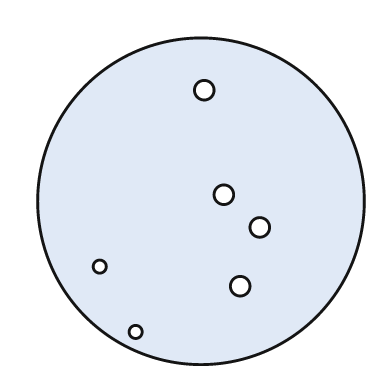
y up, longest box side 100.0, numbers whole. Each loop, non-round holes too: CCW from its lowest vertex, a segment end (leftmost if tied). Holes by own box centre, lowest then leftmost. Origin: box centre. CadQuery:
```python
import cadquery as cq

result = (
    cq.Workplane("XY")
    .moveTo(0.0, 0.0)
    .circle(50.0)
    .moveTo(-20.0, -40.0)
    .circle(2.0)
    .moveTo(12.0, -26.0)
    .circle(3.0)
    .moveTo(-31.0, -20.0)
    .circle(2.0)
    .moveTo(18.0, -8.0)
    .circle(3.0)
    .moveTo(7.0, 2.0)
    .circle(3.0)
    .moveTo(1.0, 34.0)
    .circle(3.0)
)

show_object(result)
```